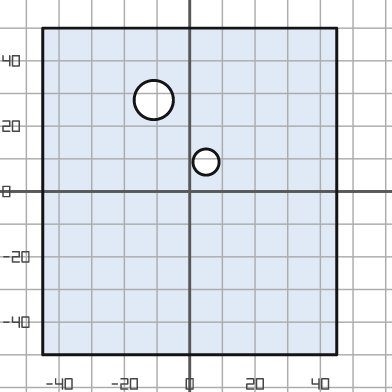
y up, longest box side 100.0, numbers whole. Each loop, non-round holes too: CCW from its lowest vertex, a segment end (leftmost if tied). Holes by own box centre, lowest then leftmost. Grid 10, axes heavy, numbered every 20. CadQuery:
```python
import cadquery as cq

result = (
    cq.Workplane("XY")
    .moveTo(-45.0, -50.0)
    .lineTo(45.0, -50.0)
    .lineTo(45.0, 50.0)
    .lineTo(-45.0, 50.0)
    .close()
    .moveTo(5.0, 9.0)
    .circle(4.0)
    .moveTo(-11.0, 28.0)
    .circle(6.0)
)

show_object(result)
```